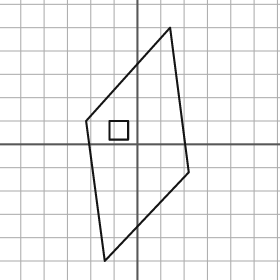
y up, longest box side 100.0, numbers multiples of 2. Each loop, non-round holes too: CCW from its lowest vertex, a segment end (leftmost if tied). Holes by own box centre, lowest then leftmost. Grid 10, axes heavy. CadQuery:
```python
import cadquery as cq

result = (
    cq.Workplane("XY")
    .moveTo(-14.0, -50.0)
    .lineTo(22.0, -12.0)
    .lineTo(14.0, 50.0)
    .lineTo(-22.0, 10.0)
    .close()
    .moveTo(-12.0, 2.0)
    .lineTo(-4.0, 2.0)
    .lineTo(-4.0, 10.0)
    .lineTo(-12.0, 10.0)
    .close()
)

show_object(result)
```